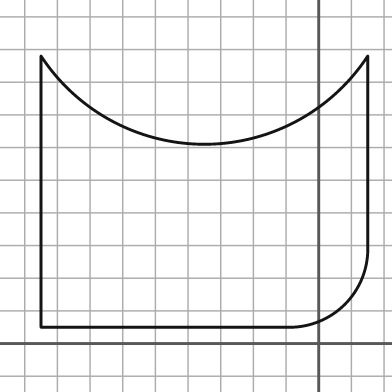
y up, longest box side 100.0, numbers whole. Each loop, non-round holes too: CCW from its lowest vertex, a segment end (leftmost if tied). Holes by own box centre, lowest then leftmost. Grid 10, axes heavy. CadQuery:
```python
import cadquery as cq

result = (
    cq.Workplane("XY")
    .moveTo(-85.0, 5.0)
    .lineTo(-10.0, 5.0)
    .threePointArc((8.0, 12.0), (15.0, 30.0))
    .lineTo(15.0, 88.0)
    .threePointArc((-35.0, 61.0), (-85.0, 88.0))
    .close()
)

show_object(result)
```